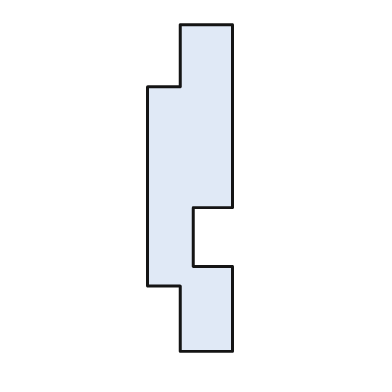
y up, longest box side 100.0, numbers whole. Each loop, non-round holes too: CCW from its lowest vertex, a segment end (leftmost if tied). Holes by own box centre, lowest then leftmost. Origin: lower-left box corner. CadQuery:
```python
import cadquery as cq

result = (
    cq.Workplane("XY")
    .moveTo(10.0, 0.0)
    .lineTo(26.0, 0.0)
    .lineTo(26.0, 26.0)
    .lineTo(14.0, 26.0)
    .lineTo(14.0, 44.0)
    .lineTo(26.0, 44.0)
    .lineTo(26.0, 100.0)
    .lineTo(10.0, 100.0)
    .lineTo(10.0, 81.0)
    .lineTo(0.0, 81.0)
    .lineTo(0.0, 20.0)
    .lineTo(10.0, 20.0)
    .close()
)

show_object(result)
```